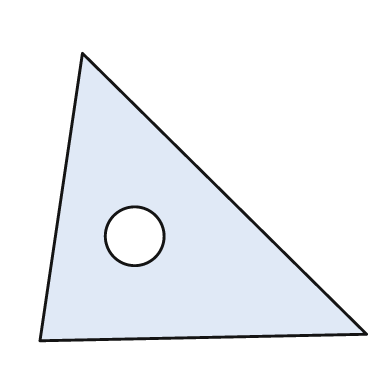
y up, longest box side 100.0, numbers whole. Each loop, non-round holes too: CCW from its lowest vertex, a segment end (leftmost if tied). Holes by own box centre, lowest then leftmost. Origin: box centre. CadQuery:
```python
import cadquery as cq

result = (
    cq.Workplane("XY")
    .moveTo(-50.0, -44.0)
    .lineTo(50.0, -42.0)
    .lineTo(-37.0, 44.0)
    .close()
    .moveTo(-21.0, -12.0)
    .circle(9.0)
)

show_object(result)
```